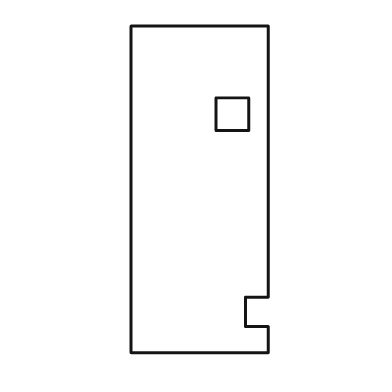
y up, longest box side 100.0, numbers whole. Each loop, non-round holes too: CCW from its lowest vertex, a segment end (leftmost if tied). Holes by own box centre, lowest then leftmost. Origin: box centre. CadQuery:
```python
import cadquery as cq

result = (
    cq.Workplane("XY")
    .moveTo(-21.0, -50.0)
    .lineTo(21.0, -50.0)
    .lineTo(21.0, -42.0)
    .lineTo(14.0, -42.0)
    .lineTo(14.0, -33.0)
    .lineTo(21.0, -33.0)
    .lineTo(21.0, 50.0)
    .lineTo(-21.0, 50.0)
    .close()
    .moveTo(5.0, 18.0)
    .lineTo(15.0, 18.0)
    .lineTo(15.0, 28.0)
    .lineTo(5.0, 28.0)
    .close()
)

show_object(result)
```